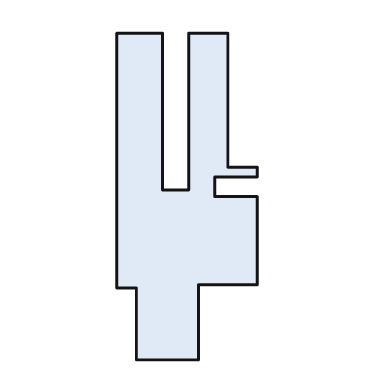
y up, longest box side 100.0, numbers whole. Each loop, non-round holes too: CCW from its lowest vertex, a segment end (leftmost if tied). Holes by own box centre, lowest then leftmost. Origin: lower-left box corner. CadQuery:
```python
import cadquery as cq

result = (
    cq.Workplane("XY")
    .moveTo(6.0, 0.0)
    .lineTo(25.0, 0.0)
    .lineTo(25.0, 23.0)
    .lineTo(43.0, 23.0)
    .lineTo(43.0, 50.0)
    .lineTo(30.0, 50.0)
    .lineTo(30.0, 56.0)
    .lineTo(43.0, 56.0)
    .lineTo(43.0, 59.0)
    .lineTo(34.0, 59.0)
    .lineTo(34.0, 100.0)
    .lineTo(22.0, 100.0)
    .lineTo(22.0, 52.0)
    .lineTo(14.0, 52.0)
    .lineTo(14.0, 100.0)
    .lineTo(0.0, 100.0)
    .lineTo(0.0, 22.0)
    .lineTo(6.0, 22.0)
    .close()
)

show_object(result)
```